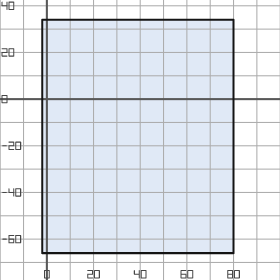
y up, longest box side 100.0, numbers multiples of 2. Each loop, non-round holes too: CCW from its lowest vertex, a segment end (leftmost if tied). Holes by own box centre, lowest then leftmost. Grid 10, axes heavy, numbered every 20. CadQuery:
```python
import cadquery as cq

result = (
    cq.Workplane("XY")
    .moveTo(-2.0, -66.0)
    .lineTo(80.0, -66.0)
    .lineTo(80.0, 34.0)
    .lineTo(-2.0, 34.0)
    .close()
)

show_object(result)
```